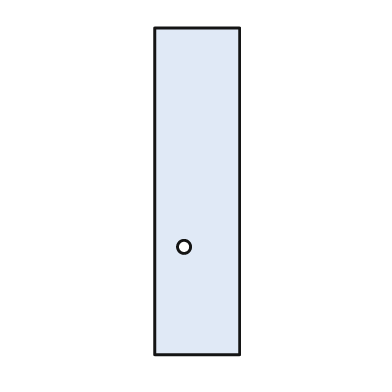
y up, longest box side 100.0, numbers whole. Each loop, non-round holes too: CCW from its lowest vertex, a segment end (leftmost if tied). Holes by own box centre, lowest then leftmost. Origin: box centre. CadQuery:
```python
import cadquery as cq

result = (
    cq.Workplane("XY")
    .moveTo(-13.0, -50.0)
    .lineTo(13.0, -50.0)
    .lineTo(13.0, 50.0)
    .lineTo(-13.0, 50.0)
    .close()
    .moveTo(-4.0, -17.0)
    .circle(2.0)
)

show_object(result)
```